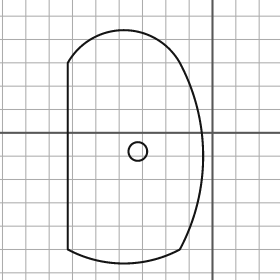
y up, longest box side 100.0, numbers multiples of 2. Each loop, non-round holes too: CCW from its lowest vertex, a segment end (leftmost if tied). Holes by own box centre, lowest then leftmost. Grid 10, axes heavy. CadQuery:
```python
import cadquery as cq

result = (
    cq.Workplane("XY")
    .moveTo(-62.0, -50.0)
    .threePointArc((-38.0, -56.0), (-14.0, -50.0))
    .threePointArc((-4.0, -10.0), (-14.0, 30.0))
    .threePointArc((-38.0, 44.0), (-62.0, 30.0))
    .close()
    .moveTo(-32.0, -8.0)
    .circle(4.0)
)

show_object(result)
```